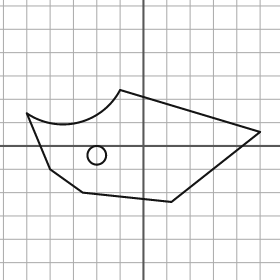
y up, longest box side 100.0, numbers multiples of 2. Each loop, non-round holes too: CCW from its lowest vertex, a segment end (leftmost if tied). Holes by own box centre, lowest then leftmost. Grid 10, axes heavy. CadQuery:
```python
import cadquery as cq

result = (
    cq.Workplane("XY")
    .moveTo(12.0, -24.0)
    .lineTo(50.0, 6.0)
    .lineTo(-10.0, 24.0)
    .threePointArc((-28.0, 10.0), (-50.0, 14.0))
    .lineTo(-40.0, -10.0)
    .lineTo(-26.0, -20.0)
    .close()
    .moveTo(-20.0, -4.0)
    .circle(4.0)
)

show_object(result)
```